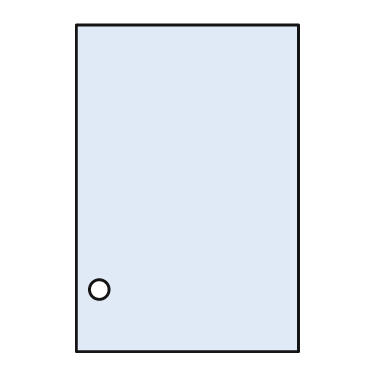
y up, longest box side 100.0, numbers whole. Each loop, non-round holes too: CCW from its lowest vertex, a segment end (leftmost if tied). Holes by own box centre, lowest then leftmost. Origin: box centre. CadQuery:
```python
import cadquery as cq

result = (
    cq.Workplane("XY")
    .moveTo(-34.0, -50.0)
    .lineTo(34.0, -50.0)
    .lineTo(34.0, 50.0)
    .lineTo(-34.0, 50.0)
    .close()
    .moveTo(-27.0, -31.0)
    .circle(3.0)
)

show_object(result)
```